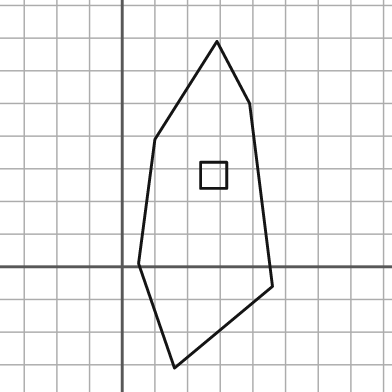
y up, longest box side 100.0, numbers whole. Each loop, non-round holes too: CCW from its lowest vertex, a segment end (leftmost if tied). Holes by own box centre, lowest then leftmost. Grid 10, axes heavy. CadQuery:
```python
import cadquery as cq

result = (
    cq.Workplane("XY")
    .moveTo(16.0, -31.0)
    .lineTo(46.0, -6.0)
    .lineTo(39.0, 50.0)
    .lineTo(29.0, 69.0)
    .lineTo(10.0, 39.0)
    .lineTo(5.0, 1.0)
    .close()
    .moveTo(24.0, 24.0)
    .lineTo(32.0, 24.0)
    .lineTo(32.0, 32.0)
    .lineTo(24.0, 32.0)
    .close()
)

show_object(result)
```